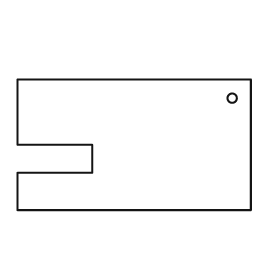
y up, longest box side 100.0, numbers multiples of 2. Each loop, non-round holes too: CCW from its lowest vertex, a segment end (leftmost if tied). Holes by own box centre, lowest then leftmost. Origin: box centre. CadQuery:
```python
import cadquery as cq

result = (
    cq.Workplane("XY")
    .moveTo(-50.0, -28.0)
    .lineTo(50.0, -28.0)
    .lineTo(50.0, 28.0)
    .lineTo(-50.0, 28.0)
    .lineTo(-50.0, 0.0)
    .lineTo(-18.0, 0.0)
    .lineTo(-18.0, -12.0)
    .lineTo(-50.0, -12.0)
    .close()
    .moveTo(42.0, 20.0)
    .circle(2.0)
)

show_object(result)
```